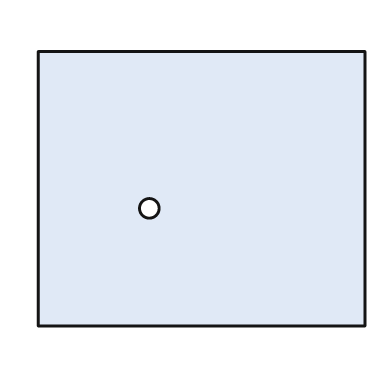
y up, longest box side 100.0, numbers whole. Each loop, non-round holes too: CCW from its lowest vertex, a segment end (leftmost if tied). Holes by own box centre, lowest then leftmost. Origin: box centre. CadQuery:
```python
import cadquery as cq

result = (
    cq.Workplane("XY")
    .moveTo(-50.0, -42.0)
    .lineTo(50.0, -42.0)
    .lineTo(50.0, 42.0)
    .lineTo(-50.0, 42.0)
    .close()
    .moveTo(-16.0, -6.0)
    .circle(3.0)
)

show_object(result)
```